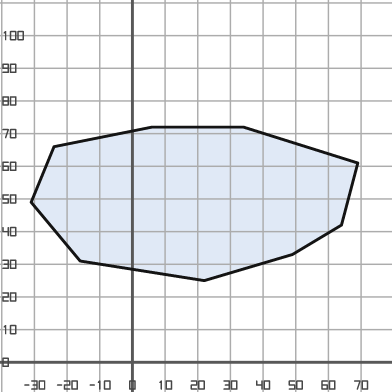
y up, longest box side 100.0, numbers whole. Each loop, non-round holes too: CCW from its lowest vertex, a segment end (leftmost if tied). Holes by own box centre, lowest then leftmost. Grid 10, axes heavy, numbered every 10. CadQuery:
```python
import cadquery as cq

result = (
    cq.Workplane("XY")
    .moveTo(22.0, 25.0)
    .lineTo(49.0, 33.0)
    .lineTo(64.0, 42.0)
    .lineTo(69.0, 61.0)
    .lineTo(34.0, 72.0)
    .lineTo(6.0, 72.0)
    .lineTo(-24.0, 66.0)
    .lineTo(-31.0, 49.0)
    .lineTo(-16.0, 31.0)
    .close()
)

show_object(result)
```